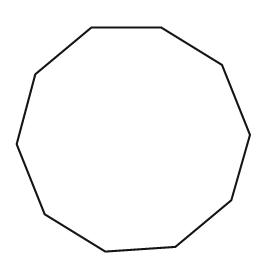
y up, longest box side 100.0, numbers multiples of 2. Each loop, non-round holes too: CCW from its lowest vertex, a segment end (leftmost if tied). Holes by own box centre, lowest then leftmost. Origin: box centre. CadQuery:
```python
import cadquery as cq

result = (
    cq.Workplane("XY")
    .moveTo(-12.0, -48.0)
    .lineTo(18.0, -46.0)
    .lineTo(42.0, -26.0)
    .lineTo(50.0, 2.0)
    .lineTo(38.0, 32.0)
    .lineTo(12.0, 48.0)
    .lineTo(-18.0, 48.0)
    .lineTo(-42.0, 28.0)
    .lineTo(-50.0, -2.0)
    .lineTo(-38.0, -32.0)
    .close()
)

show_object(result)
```